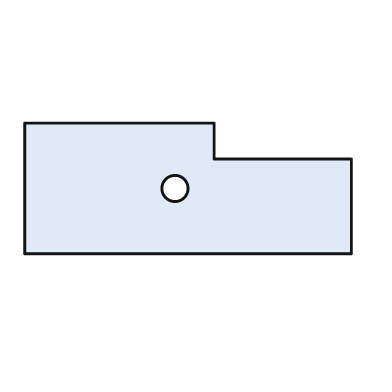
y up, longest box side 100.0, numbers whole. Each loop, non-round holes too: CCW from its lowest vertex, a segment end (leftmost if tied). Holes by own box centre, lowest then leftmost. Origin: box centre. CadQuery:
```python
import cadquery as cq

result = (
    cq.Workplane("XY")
    .moveTo(-50.0, -20.0)
    .lineTo(50.0, -20.0)
    .lineTo(50.0, 9.0)
    .lineTo(8.0, 9.0)
    .lineTo(8.0, 20.0)
    .lineTo(-50.0, 20.0)
    .close()
    .moveTo(-4.0, 0.0)
    .circle(4.0)
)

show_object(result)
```